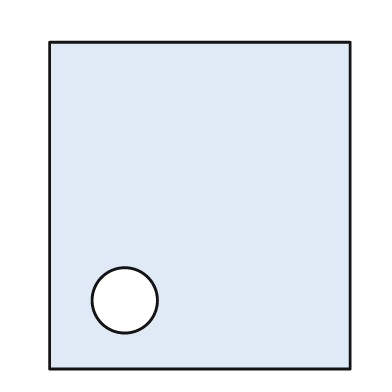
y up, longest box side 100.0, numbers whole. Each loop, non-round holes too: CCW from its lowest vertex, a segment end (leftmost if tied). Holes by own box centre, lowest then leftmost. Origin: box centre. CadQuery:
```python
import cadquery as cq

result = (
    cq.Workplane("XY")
    .moveTo(-46.0, -50.0)
    .lineTo(46.0, -50.0)
    .lineTo(46.0, 50.0)
    .lineTo(-46.0, 50.0)
    .close()
    .moveTo(-23.0, -29.0)
    .circle(10.0)
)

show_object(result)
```